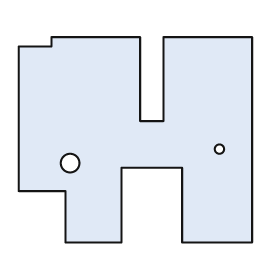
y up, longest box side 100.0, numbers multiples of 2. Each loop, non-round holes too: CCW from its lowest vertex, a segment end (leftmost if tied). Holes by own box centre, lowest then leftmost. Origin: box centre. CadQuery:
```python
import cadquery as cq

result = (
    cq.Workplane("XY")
    .moveTo(-30.0, -44.0)
    .lineTo(-6.0, -44.0)
    .lineTo(-6.0, -12.0)
    .lineTo(20.0, -12.0)
    .lineTo(20.0, -44.0)
    .lineTo(50.0, -44.0)
    .lineTo(50.0, 44.0)
    .lineTo(12.0, 44.0)
    .lineTo(12.0, 8.0)
    .lineTo(2.0, 8.0)
    .lineTo(2.0, 44.0)
    .lineTo(-36.0, 44.0)
    .lineTo(-36.0, 40.0)
    .lineTo(-50.0, 40.0)
    .lineTo(-50.0, -22.0)
    .lineTo(-30.0, -22.0)
    .close()
    .moveTo(-28.0, -10.0)
    .circle(4.0)
    .moveTo(36.0, -4.0)
    .circle(2.0)
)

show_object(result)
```